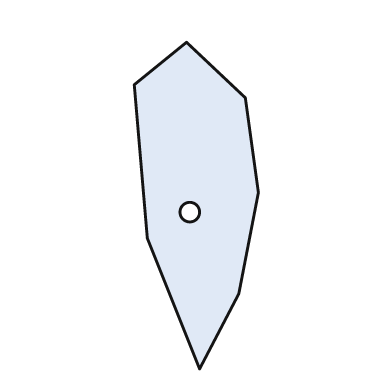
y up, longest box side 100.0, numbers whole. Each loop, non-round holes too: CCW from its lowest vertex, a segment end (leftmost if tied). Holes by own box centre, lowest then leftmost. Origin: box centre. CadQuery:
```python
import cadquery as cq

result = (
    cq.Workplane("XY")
    .moveTo(1.0, -50.0)
    .lineTo(13.0, -27.0)
    .lineTo(19.0, 4.0)
    .lineTo(15.0, 33.0)
    .lineTo(-3.0, 50.0)
    .lineTo(-19.0, 37.0)
    .lineTo(-15.0, -10.0)
    .close()
    .moveTo(-2.0, -2.0)
    .circle(3.0)
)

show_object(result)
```